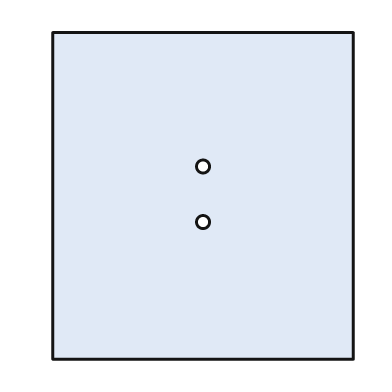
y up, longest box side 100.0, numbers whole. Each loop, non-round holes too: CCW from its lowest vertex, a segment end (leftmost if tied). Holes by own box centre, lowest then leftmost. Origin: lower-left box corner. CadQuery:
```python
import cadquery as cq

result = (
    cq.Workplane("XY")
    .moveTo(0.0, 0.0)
    .lineTo(92.0, 0.0)
    .lineTo(92.0, 100.0)
    .lineTo(0.0, 100.0)
    .close()
    .moveTo(46.0, 42.0)
    .circle(2.0)
    .moveTo(46.0, 59.0)
    .circle(2.0)
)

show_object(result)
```